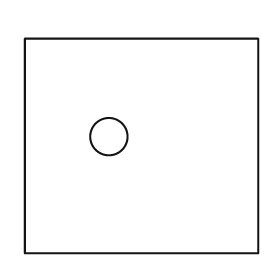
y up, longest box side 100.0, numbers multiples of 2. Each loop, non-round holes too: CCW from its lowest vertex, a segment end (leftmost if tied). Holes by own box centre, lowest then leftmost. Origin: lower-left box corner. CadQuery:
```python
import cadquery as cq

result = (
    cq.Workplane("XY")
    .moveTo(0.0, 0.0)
    .lineTo(100.0, 0.0)
    .lineTo(100.0, 92.0)
    .lineTo(0.0, 92.0)
    .close()
    .moveTo(36.0, 50.0)
    .circle(8.0)
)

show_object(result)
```